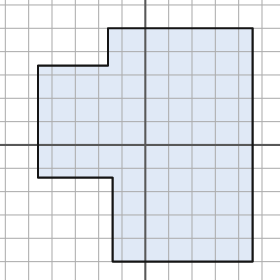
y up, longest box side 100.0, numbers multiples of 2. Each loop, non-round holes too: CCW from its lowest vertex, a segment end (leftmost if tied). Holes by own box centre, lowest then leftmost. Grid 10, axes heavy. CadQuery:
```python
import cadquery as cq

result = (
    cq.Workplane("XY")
    .moveTo(-14.0, -50.0)
    .lineTo(46.0, -50.0)
    .lineTo(46.0, 50.0)
    .lineTo(-16.0, 50.0)
    .lineTo(-16.0, 34.0)
    .lineTo(-46.0, 34.0)
    .lineTo(-46.0, -14.0)
    .lineTo(-14.0, -14.0)
    .close()
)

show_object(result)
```